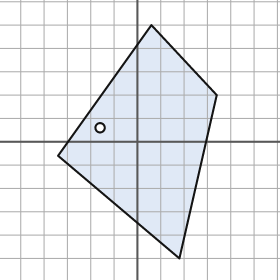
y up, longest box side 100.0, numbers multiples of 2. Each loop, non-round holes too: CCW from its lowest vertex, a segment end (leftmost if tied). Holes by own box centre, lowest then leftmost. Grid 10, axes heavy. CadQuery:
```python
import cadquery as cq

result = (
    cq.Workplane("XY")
    .moveTo(18.0, -50.0)
    .lineTo(34.0, 20.0)
    .lineTo(6.0, 50.0)
    .lineTo(-34.0, -6.0)
    .close()
    .moveTo(-16.0, 6.0)
    .circle(2.0)
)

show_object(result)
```